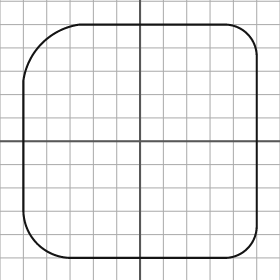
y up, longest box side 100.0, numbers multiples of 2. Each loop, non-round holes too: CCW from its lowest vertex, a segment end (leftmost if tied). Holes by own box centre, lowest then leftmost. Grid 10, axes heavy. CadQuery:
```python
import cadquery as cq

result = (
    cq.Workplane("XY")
    .moveTo(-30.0, -50.0)
    .lineTo(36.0, -50.0)
    .threePointArc((46.0, -46.0), (50.0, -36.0))
    .lineTo(50.0, 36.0)
    .threePointArc((46.0, 46.0), (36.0, 50.0))
    .lineTo(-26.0, 50.0)
    .threePointArc((-42.0, 42.0), (-50.0, 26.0))
    .lineTo(-50.0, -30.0)
    .threePointArc((-44.0, -44.0), (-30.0, -50.0))
    .close()
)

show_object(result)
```